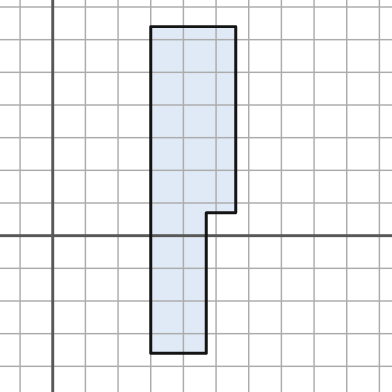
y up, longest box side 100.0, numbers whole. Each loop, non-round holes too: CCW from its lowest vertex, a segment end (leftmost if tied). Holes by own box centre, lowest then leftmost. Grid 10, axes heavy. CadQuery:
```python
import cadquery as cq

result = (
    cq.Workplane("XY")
    .moveTo(30.0, -36.0)
    .lineTo(47.0, -36.0)
    .lineTo(47.0, 7.0)
    .lineTo(56.0, 7.0)
    .lineTo(56.0, 64.0)
    .lineTo(30.0, 64.0)
    .close()
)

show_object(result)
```